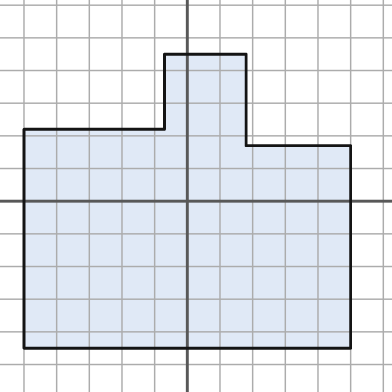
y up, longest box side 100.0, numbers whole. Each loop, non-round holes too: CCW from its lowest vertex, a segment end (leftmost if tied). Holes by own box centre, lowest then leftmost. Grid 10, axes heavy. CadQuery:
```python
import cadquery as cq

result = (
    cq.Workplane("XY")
    .moveTo(-50.0, -45.0)
    .lineTo(50.0, -45.0)
    .lineTo(50.0, 17.0)
    .lineTo(18.0, 17.0)
    .lineTo(18.0, 45.0)
    .lineTo(-7.0, 45.0)
    .lineTo(-7.0, 22.0)
    .lineTo(-50.0, 22.0)
    .close()
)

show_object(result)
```